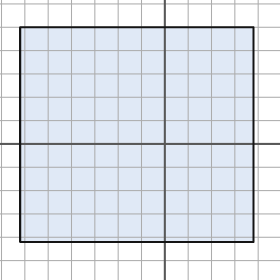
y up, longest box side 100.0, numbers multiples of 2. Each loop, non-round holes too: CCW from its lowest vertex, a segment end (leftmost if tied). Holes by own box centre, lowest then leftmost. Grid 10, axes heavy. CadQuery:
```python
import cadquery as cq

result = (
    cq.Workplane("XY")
    .moveTo(-62.0, -42.0)
    .lineTo(38.0, -42.0)
    .lineTo(38.0, 50.0)
    .lineTo(-62.0, 50.0)
    .close()
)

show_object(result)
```